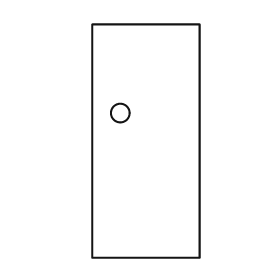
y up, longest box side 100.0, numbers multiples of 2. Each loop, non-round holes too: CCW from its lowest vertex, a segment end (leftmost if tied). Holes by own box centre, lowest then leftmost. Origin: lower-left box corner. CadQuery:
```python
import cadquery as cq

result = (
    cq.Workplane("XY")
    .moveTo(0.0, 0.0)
    .lineTo(46.0, 0.0)
    .lineTo(46.0, 100.0)
    .lineTo(0.0, 100.0)
    .close()
    .moveTo(12.0, 62.0)
    .circle(4.0)
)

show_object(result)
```